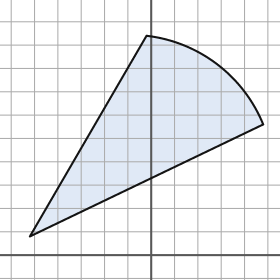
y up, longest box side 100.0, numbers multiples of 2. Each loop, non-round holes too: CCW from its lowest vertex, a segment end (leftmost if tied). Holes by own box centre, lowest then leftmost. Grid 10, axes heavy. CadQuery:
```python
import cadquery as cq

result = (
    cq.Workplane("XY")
    .moveTo(-52.0, 8.0)
    .lineTo(48.0, 56.0)
    .threePointArc((28.0, 82.0), (-2.0, 94.0))
    .close()
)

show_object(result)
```